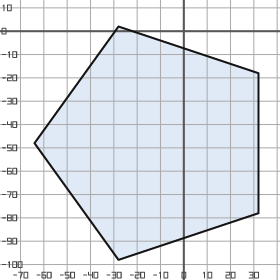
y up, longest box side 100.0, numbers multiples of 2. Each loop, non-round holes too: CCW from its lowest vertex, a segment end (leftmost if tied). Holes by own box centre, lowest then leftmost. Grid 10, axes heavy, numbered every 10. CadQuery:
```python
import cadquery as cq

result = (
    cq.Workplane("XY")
    .moveTo(-28.0, -98.0)
    .lineTo(32.0, -78.0)
    .lineTo(32.0, -18.0)
    .lineTo(-28.0, 2.0)
    .lineTo(-64.0, -48.0)
    .close()
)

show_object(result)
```